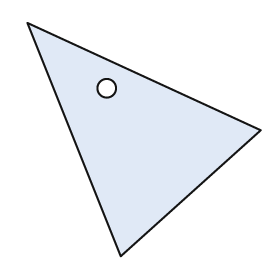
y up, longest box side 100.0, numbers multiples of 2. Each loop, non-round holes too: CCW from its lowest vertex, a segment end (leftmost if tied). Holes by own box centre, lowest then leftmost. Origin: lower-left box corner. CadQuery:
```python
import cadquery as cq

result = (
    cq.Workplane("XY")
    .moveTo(40.0, 0.0)
    .lineTo(100.0, 54.0)
    .lineTo(0.0, 100.0)
    .close()
    .moveTo(34.0, 72.0)
    .circle(4.0)
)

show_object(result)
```